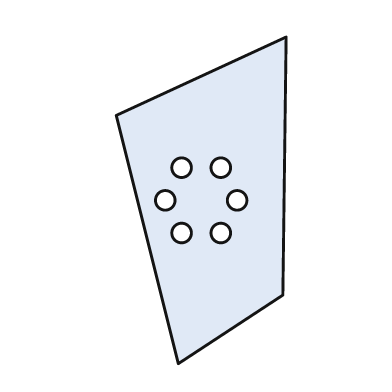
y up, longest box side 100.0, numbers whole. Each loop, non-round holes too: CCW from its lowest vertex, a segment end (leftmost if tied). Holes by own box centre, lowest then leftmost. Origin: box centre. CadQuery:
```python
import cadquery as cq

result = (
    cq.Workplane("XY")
    .moveTo(-7.0, -50.0)
    .lineTo(25.0, -29.0)
    .lineTo(26.0, 50.0)
    .lineTo(-26.0, 26.0)
    .close()
    .moveTo(-6.0, -10.0)
    .circle(3.0)
    .moveTo(6.0, -10.0)
    .circle(3.0)
    .moveTo(-11.0, 0.0)
    .circle(3.0)
    .moveTo(11.0, 0.0)
    .circle(3.0)
    .moveTo(-6.0, 10.0)
    .circle(3.0)
    .moveTo(6.0, 10.0)
    .circle(3.0)
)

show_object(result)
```